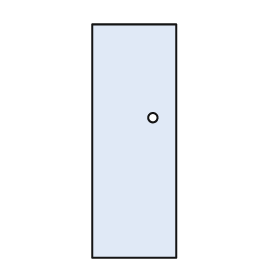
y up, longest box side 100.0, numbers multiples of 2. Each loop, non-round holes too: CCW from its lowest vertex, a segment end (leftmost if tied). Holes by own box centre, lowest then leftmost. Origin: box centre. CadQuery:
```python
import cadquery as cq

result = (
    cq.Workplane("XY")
    .moveTo(-18.0, -50.0)
    .lineTo(18.0, -50.0)
    .lineTo(18.0, 50.0)
    .lineTo(-18.0, 50.0)
    .close()
    .moveTo(8.0, 10.0)
    .circle(2.0)
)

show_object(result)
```